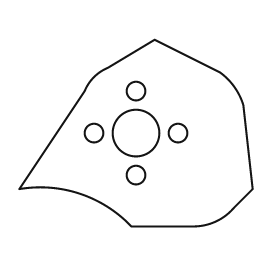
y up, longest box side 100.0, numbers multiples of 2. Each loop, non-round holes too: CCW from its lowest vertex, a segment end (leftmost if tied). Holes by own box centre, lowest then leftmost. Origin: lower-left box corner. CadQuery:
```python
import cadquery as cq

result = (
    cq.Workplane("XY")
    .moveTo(48.0, 0.0)
    .lineTo(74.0, 0.0)
    .threePointArc((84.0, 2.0), (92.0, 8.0))
    .lineTo(100.0, 16.0)
    .lineTo(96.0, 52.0)
    .threePointArc((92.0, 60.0), (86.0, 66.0))
    .lineTo(58.0, 80.0)
    .lineTo(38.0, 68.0)
    .threePointArc((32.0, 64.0), (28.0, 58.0))
    .lineTo(0.0, 16.0)
    .threePointArc((26.0, 14.0), (48.0, 0.0))
    .close()
    .moveTo(50.0, 22.0)
    .circle(4.0)
    .moveTo(32.0, 40.0)
    .circle(4.0)
    .moveTo(50.0, 40.0)
    .circle(10.0)
    .moveTo(68.0, 40.0)
    .circle(4.0)
    .moveTo(50.0, 58.0)
    .circle(4.0)
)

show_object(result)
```